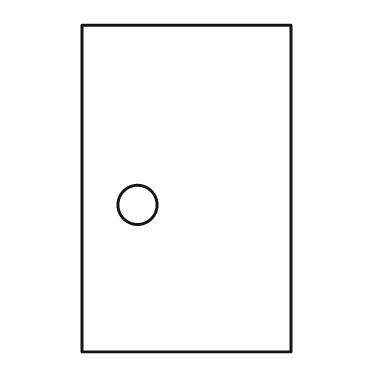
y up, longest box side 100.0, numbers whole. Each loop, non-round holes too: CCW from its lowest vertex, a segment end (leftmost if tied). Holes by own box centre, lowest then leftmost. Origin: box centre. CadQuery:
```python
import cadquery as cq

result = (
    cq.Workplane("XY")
    .moveTo(-32.0, -50.0)
    .lineTo(32.0, -50.0)
    .lineTo(32.0, 50.0)
    .lineTo(-32.0, 50.0)
    .close()
    .moveTo(-15.0, -5.0)
    .circle(6.0)
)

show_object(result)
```